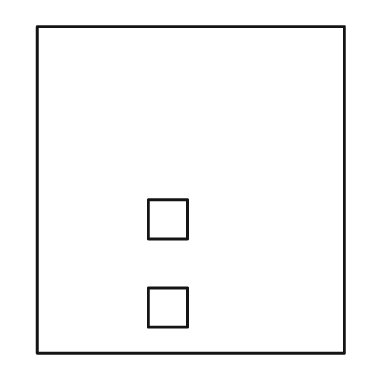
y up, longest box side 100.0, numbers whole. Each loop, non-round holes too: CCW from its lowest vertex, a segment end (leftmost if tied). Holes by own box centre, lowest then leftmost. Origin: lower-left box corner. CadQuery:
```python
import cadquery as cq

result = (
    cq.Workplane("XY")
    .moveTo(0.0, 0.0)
    .lineTo(94.0, 0.0)
    .lineTo(94.0, 100.0)
    .lineTo(0.0, 100.0)
    .close()
    .moveTo(34.0, 8.0)
    .lineTo(46.0, 8.0)
    .lineTo(46.0, 20.0)
    .lineTo(34.0, 20.0)
    .close()
    .moveTo(34.0, 35.0)
    .lineTo(46.0, 35.0)
    .lineTo(46.0, 47.0)
    .lineTo(34.0, 47.0)
    .close()
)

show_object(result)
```